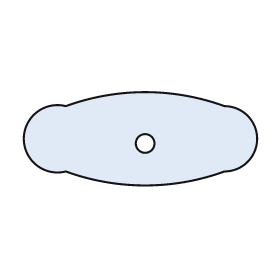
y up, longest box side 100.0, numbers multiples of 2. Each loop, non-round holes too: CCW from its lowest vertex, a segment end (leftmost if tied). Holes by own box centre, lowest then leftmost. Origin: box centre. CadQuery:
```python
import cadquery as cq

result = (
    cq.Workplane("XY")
    .moveTo(-32.0, -14.0)
    .threePointArc((2.0, -20.0), (36.0, -14.0))
    .threePointArc((50.0, 0.0), (36.0, 14.0))
    .threePointArc((2.0, 20.0), (-32.0, 14.0))
    .threePointArc((-50.0, 0.0), (-32.0, -14.0))
    .close()
    .moveTo(2.0, -2.0)
    .circle(4.0)
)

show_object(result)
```